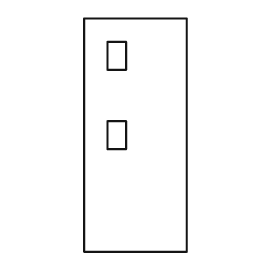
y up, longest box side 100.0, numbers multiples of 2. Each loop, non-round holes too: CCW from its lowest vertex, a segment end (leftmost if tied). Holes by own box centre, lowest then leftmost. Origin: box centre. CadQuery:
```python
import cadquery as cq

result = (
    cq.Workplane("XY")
    .moveTo(-22.0, -50.0)
    .lineTo(22.0, -50.0)
    .lineTo(22.0, 50.0)
    .lineTo(-22.0, 50.0)
    .close()
    .moveTo(-12.0, -6.0)
    .lineTo(-4.0, -6.0)
    .lineTo(-4.0, 6.0)
    .lineTo(-12.0, 6.0)
    .close()
    .moveTo(-12.0, 28.0)
    .lineTo(-4.0, 28.0)
    .lineTo(-4.0, 40.0)
    .lineTo(-12.0, 40.0)
    .close()
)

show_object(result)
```